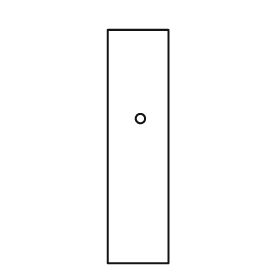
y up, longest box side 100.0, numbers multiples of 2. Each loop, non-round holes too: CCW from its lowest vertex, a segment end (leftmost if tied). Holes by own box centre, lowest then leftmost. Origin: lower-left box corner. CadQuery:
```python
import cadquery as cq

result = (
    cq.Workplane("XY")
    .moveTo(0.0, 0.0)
    .lineTo(26.0, 0.0)
    .lineTo(26.0, 100.0)
    .lineTo(0.0, 100.0)
    .close()
    .moveTo(14.0, 62.0)
    .circle(2.0)
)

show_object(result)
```